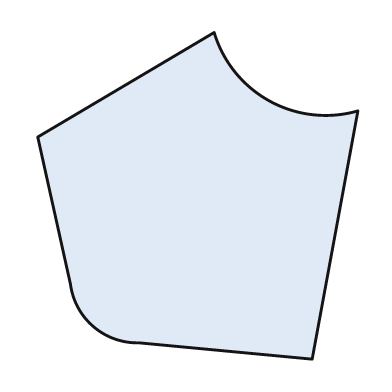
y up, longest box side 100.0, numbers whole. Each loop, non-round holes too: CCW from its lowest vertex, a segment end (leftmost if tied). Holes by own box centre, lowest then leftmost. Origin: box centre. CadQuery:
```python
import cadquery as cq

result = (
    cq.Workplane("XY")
    .moveTo(35.0, -50.0)
    .lineTo(49.0, 26.0)
    .threePointArc((22.0, 29.0), (5.0, 50.0))
    .lineTo(-49.0, 18.0)
    .lineTo(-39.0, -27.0)
    .threePointArc((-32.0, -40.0), (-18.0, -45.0))
    .close()
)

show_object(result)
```